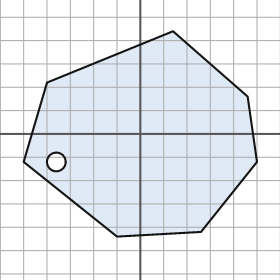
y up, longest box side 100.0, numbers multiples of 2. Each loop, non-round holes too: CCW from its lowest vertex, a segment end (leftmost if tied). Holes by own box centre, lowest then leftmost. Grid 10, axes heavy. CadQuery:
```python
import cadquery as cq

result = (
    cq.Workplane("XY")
    .moveTo(-10.0, -44.0)
    .lineTo(26.0, -42.0)
    .lineTo(50.0, -12.0)
    .lineTo(46.0, 16.0)
    .lineTo(14.0, 44.0)
    .lineTo(-40.0, 22.0)
    .lineTo(-50.0, -12.0)
    .close()
    .moveTo(-36.0, -12.0)
    .circle(4.0)
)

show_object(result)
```